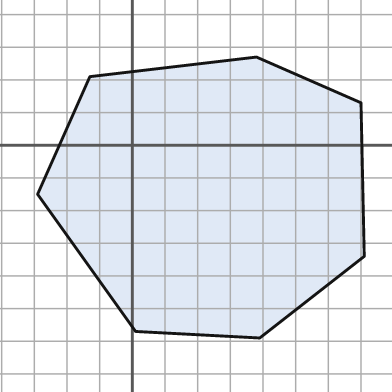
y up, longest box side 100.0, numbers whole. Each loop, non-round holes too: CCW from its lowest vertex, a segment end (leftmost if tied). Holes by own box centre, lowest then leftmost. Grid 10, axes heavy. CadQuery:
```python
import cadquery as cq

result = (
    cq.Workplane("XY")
    .moveTo(39.0, -59.0)
    .lineTo(71.0, -34.0)
    .lineTo(70.0, 13.0)
    .lineTo(38.0, 27.0)
    .lineTo(-13.0, 21.0)
    .lineTo(-29.0, -15.0)
    .lineTo(1.0, -57.0)
    .close()
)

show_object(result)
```